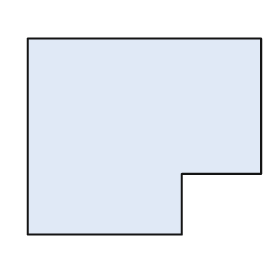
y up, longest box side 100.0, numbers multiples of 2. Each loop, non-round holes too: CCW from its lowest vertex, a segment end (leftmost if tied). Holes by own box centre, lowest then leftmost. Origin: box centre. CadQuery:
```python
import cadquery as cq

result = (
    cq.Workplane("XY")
    .moveTo(-50.0, -42.0)
    .lineTo(16.0, -42.0)
    .lineTo(16.0, -16.0)
    .lineTo(50.0, -16.0)
    .lineTo(50.0, 42.0)
    .lineTo(-50.0, 42.0)
    .close()
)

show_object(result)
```